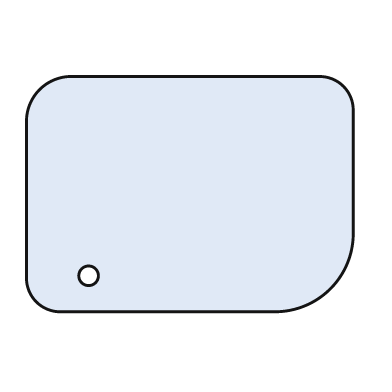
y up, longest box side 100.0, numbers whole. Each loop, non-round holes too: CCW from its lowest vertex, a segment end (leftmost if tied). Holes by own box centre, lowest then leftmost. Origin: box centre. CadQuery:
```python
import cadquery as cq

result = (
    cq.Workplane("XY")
    .moveTo(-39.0, -36.0)
    .lineTo(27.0, -36.0)
    .threePointArc((43.0, -29.0), (50.0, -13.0))
    .lineTo(50.0, 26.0)
    .threePointArc((47.0, 33.0), (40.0, 36.0))
    .lineTo(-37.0, 36.0)
    .threePointArc((-46.0, 32.0), (-50.0, 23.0))
    .lineTo(-50.0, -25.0)
    .threePointArc((-47.0, -33.0), (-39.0, -36.0))
    .close()
    .moveTo(-31.0, -25.0)
    .circle(3.0)
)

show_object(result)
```